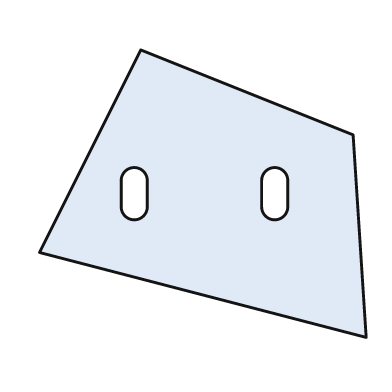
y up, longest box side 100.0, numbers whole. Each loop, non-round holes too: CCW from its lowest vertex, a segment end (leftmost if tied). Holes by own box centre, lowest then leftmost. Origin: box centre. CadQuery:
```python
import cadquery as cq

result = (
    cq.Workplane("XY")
    .moveTo(50.0, -44.0)
    .lineTo(46.0, 18.0)
    .lineTo(-19.0, 44.0)
    .lineTo(-50.0, -18.0)
    .close()
    .moveTo(-25.0, -4.0)
    .threePointArc((-21.0, -8.0), (-17.0, -4.0))
    .lineTo(-17.0, 4.0)
    .threePointArc((-21.0, 8.0), (-25.0, 4.0))
    .close()
    .moveTo(18.0, -4.0)
    .threePointArc((22.0, -8.0), (26.0, -4.0))
    .lineTo(26.0, 4.0)
    .threePointArc((22.0, 8.0), (18.0, 4.0))
    .close()
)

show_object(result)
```